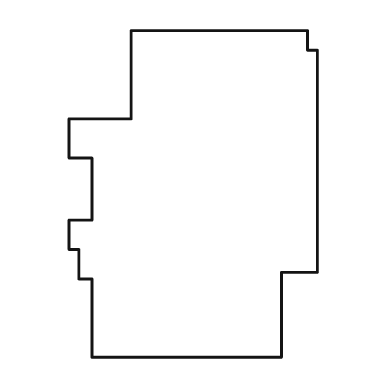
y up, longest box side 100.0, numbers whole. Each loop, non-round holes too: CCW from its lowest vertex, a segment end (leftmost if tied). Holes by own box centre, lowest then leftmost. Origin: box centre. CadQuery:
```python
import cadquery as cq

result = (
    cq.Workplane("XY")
    .moveTo(-31.0, -50.0)
    .lineTo(27.0, -50.0)
    .lineTo(27.0, -24.0)
    .lineTo(38.0, -24.0)
    .lineTo(38.0, 44.0)
    .lineTo(35.0, 44.0)
    .lineTo(35.0, 50.0)
    .lineTo(-19.0, 50.0)
    .lineTo(-19.0, 23.0)
    .lineTo(-38.0, 23.0)
    .lineTo(-38.0, 11.0)
    .lineTo(-31.0, 11.0)
    .lineTo(-31.0, -8.0)
    .lineTo(-38.0, -8.0)
    .lineTo(-38.0, -17.0)
    .lineTo(-35.0, -17.0)
    .lineTo(-35.0, -26.0)
    .lineTo(-31.0, -26.0)
    .close()
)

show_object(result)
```